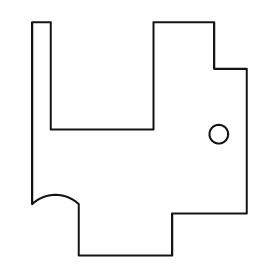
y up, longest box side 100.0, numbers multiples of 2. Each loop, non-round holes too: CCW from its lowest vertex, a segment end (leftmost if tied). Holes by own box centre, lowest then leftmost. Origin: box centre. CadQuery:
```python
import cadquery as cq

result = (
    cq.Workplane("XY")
    .moveTo(-26.0, -50.0)
    .lineTo(14.0, -50.0)
    .lineTo(14.0, -32.0)
    .lineTo(46.0, -32.0)
    .lineTo(46.0, 30.0)
    .lineTo(32.0, 30.0)
    .lineTo(32.0, 50.0)
    .lineTo(6.0, 50.0)
    .lineTo(6.0, 4.0)
    .lineTo(-38.0, 4.0)
    .lineTo(-38.0, 50.0)
    .lineTo(-46.0, 50.0)
    .lineTo(-46.0, -28.0)
    .threePointArc((-36.0, -24.0), (-26.0, -28.0))
    .close()
    .moveTo(34.0, 2.0)
    .circle(4.0)
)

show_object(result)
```